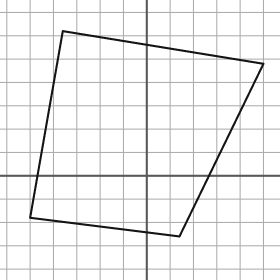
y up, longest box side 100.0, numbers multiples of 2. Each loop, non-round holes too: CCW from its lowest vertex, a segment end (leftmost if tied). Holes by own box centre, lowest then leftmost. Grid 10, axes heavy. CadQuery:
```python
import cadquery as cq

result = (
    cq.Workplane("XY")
    .moveTo(14.0, -26.0)
    .lineTo(50.0, 48.0)
    .lineTo(-36.0, 62.0)
    .lineTo(-50.0, -18.0)
    .close()
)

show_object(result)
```